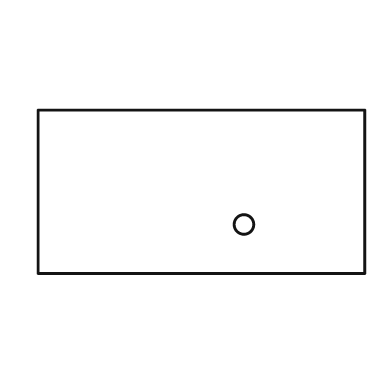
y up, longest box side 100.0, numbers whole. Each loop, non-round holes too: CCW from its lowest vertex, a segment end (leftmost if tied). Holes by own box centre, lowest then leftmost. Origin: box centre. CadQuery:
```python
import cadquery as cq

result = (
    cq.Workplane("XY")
    .moveTo(-50.0, -25.0)
    .lineTo(50.0, -25.0)
    .lineTo(50.0, 25.0)
    .lineTo(-50.0, 25.0)
    .close()
    .moveTo(13.0, -10.0)
    .circle(3.0)
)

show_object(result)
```